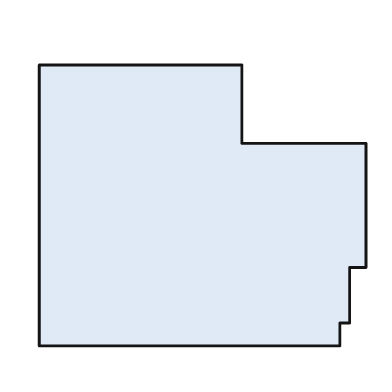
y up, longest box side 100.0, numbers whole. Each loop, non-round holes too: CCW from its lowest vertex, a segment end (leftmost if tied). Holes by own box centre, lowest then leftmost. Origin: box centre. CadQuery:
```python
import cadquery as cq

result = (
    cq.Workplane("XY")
    .moveTo(-50.0, -43.0)
    .lineTo(42.0, -43.0)
    .lineTo(42.0, -36.0)
    .lineTo(45.0, -36.0)
    .lineTo(45.0, -19.0)
    .lineTo(50.0, -19.0)
    .lineTo(50.0, 19.0)
    .lineTo(12.0, 19.0)
    .lineTo(12.0, 43.0)
    .lineTo(-50.0, 43.0)
    .close()
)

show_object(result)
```